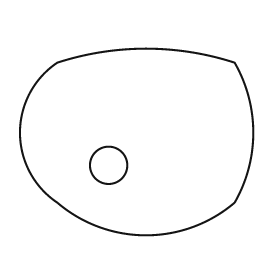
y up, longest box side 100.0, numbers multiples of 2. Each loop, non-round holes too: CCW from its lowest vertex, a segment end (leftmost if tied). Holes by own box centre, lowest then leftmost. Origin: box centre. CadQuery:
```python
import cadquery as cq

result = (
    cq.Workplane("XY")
    .moveTo(-34.0, -26.0)
    .threePointArc((4.0, -40.0), (42.0, -26.0))
    .threePointArc((50.0, 4.0), (42.0, 34.0))
    .threePointArc((4.0, 40.0), (-34.0, 34.0))
    .threePointArc((-50.0, 4.0), (-34.0, -26.0))
    .close()
    .moveTo(-12.0, -10.0)
    .circle(8.0)
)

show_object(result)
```